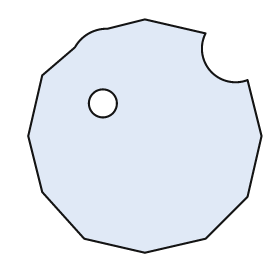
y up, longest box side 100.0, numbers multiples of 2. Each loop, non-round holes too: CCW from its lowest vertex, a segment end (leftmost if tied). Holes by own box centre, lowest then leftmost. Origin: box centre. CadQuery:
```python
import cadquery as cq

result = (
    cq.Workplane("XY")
    .moveTo(0.0, -50.0)
    .lineTo(26.0, -44.0)
    .lineTo(44.0, -26.0)
    .lineTo(50.0, 0.0)
    .lineTo(44.0, 24.0)
    .threePointArc((28.0, 28.0), (26.0, 44.0))
    .lineTo(0.0, 50.0)
    .lineTo(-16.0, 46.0)
    .threePointArc((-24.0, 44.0), (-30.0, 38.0))
    .lineTo(-44.0, 26.0)
    .lineTo(-50.0, 0.0)
    .lineTo(-44.0, -24.0)
    .lineTo(-26.0, -44.0)
    .close()
    .moveTo(-18.0, 14.0)
    .circle(6.0)
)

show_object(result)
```